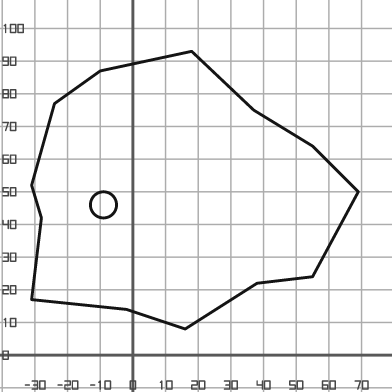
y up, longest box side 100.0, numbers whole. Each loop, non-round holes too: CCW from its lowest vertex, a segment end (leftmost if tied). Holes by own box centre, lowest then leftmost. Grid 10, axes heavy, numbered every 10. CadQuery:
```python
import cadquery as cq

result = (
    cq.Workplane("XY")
    .moveTo(16.0, 8.0)
    .lineTo(38.0, 22.0)
    .lineTo(55.0, 24.0)
    .lineTo(69.0, 50.0)
    .lineTo(55.0, 64.0)
    .lineTo(37.0, 75.0)
    .lineTo(18.0, 93.0)
    .lineTo(-10.0, 87.0)
    .lineTo(-24.0, 77.0)
    .lineTo(-31.0, 52.0)
    .lineTo(-28.0, 42.0)
    .lineTo(-31.0, 17.0)
    .lineTo(-2.0, 14.0)
    .close()
    .moveTo(-9.0, 46.0)
    .circle(4.0)
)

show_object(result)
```